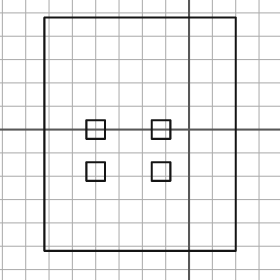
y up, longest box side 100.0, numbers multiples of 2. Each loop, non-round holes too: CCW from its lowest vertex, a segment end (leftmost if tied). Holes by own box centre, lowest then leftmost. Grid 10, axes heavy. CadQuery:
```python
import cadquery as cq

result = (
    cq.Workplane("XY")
    .moveTo(-62.0, -52.0)
    .lineTo(20.0, -52.0)
    .lineTo(20.0, 48.0)
    .lineTo(-62.0, 48.0)
    .close()
    .moveTo(-44.0, -22.0)
    .lineTo(-36.0, -22.0)
    .lineTo(-36.0, -14.0)
    .lineTo(-44.0, -14.0)
    .close()
    .moveTo(-16.0, -22.0)
    .lineTo(-8.0, -22.0)
    .lineTo(-8.0, -14.0)
    .lineTo(-16.0, -14.0)
    .close()
    .moveTo(-44.0, -4.0)
    .lineTo(-36.0, -4.0)
    .lineTo(-36.0, 4.0)
    .lineTo(-44.0, 4.0)
    .close()
    .moveTo(-16.0, -4.0)
    .lineTo(-8.0, -4.0)
    .lineTo(-8.0, 4.0)
    .lineTo(-16.0, 4.0)
    .close()
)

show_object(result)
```